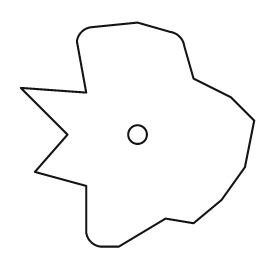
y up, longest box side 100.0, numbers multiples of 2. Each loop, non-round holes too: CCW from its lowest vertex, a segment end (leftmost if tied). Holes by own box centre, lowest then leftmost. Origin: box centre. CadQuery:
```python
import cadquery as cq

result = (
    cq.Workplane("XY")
    .moveTo(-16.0, -48.0)
    .lineTo(-8.0, -48.0)
    .lineTo(12.0, -36.0)
    .lineTo(24.0, -38.0)
    .lineTo(36.0, -28.0)
    .lineTo(46.0, -14.0)
    .lineTo(50.0, 6.0)
    .lineTo(40.0, 16.0)
    .lineTo(24.0, 24.0)
    .lineTo(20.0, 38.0)
    .threePointArc((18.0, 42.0), (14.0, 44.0))
    .lineTo(0.0, 48.0)
    .lineTo(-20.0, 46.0)
    .threePointArc((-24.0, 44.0), (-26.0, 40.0))
    .lineTo(-22.0, 18.0)
    .lineTo(-50.0, 20.0)
    .lineTo(-30.0, 0.0)
    .lineTo(-44.0, -16.0)
    .lineTo(-22.0, -22.0)
    .lineTo(-22.0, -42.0)
    .threePointArc((-20.0, -46.0), (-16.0, -48.0))
    .close()
    .moveTo(0.0, 0.0)
    .circle(4.0)
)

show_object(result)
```